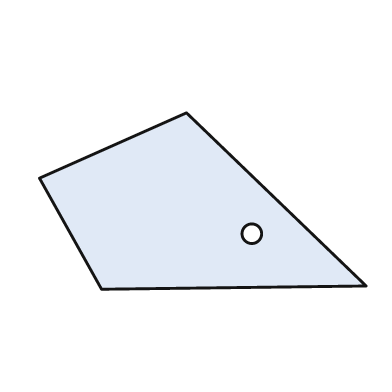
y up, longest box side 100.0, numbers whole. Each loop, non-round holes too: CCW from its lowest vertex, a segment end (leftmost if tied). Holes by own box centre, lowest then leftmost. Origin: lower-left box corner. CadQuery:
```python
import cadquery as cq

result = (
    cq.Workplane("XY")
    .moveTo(19.0, 0.0)
    .lineTo(100.0, 1.0)
    .lineTo(45.0, 54.0)
    .lineTo(0.0, 34.0)
    .close()
    .moveTo(65.0, 17.0)
    .circle(3.0)
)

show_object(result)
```